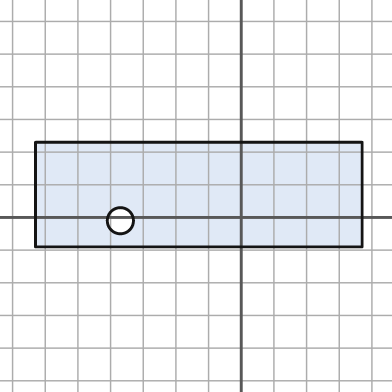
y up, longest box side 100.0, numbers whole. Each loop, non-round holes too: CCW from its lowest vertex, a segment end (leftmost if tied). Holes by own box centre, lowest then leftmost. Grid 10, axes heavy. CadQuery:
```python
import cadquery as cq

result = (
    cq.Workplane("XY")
    .moveTo(-63.0, -9.0)
    .lineTo(37.0, -9.0)
    .lineTo(37.0, 23.0)
    .lineTo(-63.0, 23.0)
    .close()
    .moveTo(-37.0, -1.0)
    .circle(4.0)
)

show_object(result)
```